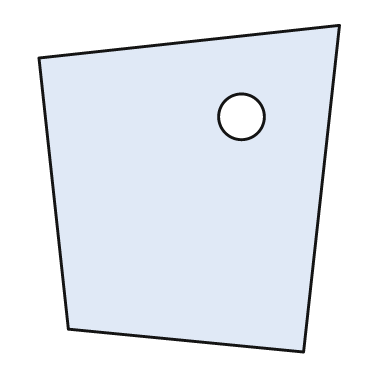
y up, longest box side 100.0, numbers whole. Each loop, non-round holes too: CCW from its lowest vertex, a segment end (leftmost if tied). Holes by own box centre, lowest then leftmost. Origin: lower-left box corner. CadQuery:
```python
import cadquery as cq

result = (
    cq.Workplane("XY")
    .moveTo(81.0, 0.0)
    .lineTo(92.0, 100.0)
    .lineTo(0.0, 90.0)
    .lineTo(9.0, 7.0)
    .close()
    .moveTo(62.0, 72.0)
    .circle(7.0)
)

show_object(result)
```